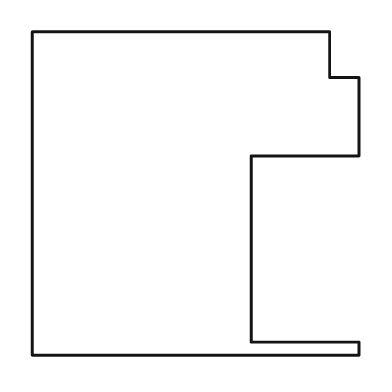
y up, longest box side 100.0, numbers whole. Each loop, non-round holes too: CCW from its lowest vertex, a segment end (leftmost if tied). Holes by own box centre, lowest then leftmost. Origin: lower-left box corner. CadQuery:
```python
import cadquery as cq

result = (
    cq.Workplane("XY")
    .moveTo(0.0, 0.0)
    .lineTo(100.0, 0.0)
    .lineTo(100.0, 4.0)
    .lineTo(67.0, 4.0)
    .lineTo(67.0, 61.0)
    .lineTo(100.0, 61.0)
    .lineTo(100.0, 85.0)
    .lineTo(91.0, 85.0)
    .lineTo(91.0, 99.0)
    .lineTo(0.0, 99.0)
    .close()
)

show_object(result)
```